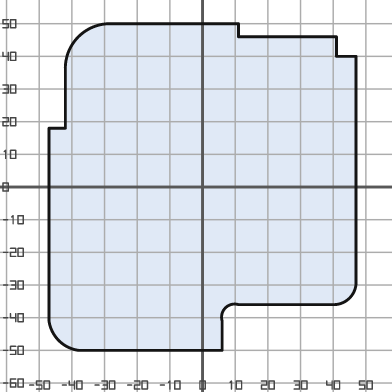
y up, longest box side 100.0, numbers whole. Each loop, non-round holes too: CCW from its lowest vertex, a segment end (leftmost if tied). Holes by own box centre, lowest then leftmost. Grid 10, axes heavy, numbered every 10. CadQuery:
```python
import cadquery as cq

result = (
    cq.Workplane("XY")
    .moveTo(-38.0, -50.0)
    .lineTo(6.0, -50.0)
    .lineTo(6.0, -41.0)
    .threePointArc((7.0, -37.0), (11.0, -36.0))
    .lineTo(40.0, -36.0)
    .threePointArc((45.0, -34.0), (47.0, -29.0))
    .lineTo(47.0, 40.0)
    .lineTo(41.0, 40.0)
    .lineTo(41.0, 46.0)
    .lineTo(11.0, 46.0)
    .lineTo(11.0, 50.0)
    .lineTo(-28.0, 50.0)
    .threePointArc((-38.0, 46.0), (-42.0, 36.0))
    .lineTo(-42.0, 18.0)
    .lineTo(-47.0, 18.0)
    .lineTo(-47.0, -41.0)
    .threePointArc((-44.0, -47.0), (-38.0, -50.0))
    .close()
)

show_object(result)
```